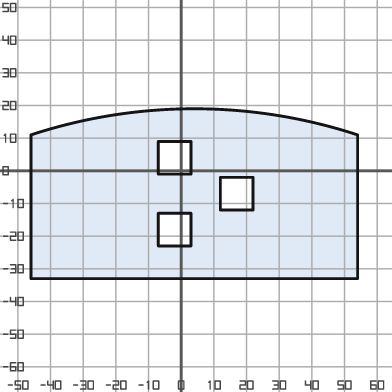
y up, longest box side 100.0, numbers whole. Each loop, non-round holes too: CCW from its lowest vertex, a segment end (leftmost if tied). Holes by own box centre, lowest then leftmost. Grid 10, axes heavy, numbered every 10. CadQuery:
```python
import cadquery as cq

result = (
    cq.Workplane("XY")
    .moveTo(-46.0, -33.0)
    .lineTo(54.0, -33.0)
    .lineTo(54.0, 11.0)
    .threePointArc((4.0, 19.0), (-46.0, 11.0))
    .close()
    .moveTo(-7.0, -23.0)
    .lineTo(3.0, -23.0)
    .lineTo(3.0, -13.0)
    .lineTo(-7.0, -13.0)
    .close()
    .moveTo(12.0, -12.0)
    .lineTo(22.0, -12.0)
    .lineTo(22.0, -2.0)
    .lineTo(12.0, -2.0)
    .close()
    .moveTo(-7.0, -1.0)
    .lineTo(3.0, -1.0)
    .lineTo(3.0, 9.0)
    .lineTo(-7.0, 9.0)
    .close()
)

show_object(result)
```